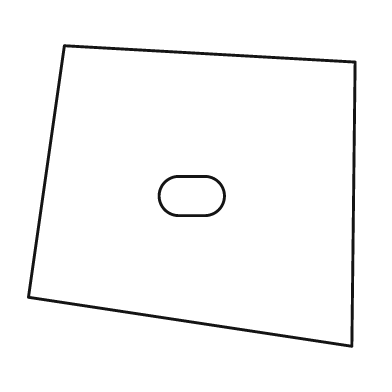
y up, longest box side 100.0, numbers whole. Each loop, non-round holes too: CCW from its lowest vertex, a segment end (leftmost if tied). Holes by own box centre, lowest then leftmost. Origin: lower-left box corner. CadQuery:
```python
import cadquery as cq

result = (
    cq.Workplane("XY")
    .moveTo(99.0, 0.0)
    .lineTo(100.0, 87.0)
    .lineTo(11.0, 92.0)
    .lineTo(0.0, 15.0)
    .close()
    .moveTo(46.0, 40.0)
    .lineTo(54.0, 40.0)
    .threePointArc((60.0, 46.0), (54.0, 52.0))
    .lineTo(46.0, 52.0)
    .threePointArc((40.0, 46.0), (46.0, 40.0))
    .close()
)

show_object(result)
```